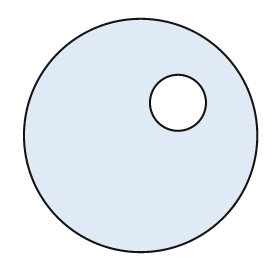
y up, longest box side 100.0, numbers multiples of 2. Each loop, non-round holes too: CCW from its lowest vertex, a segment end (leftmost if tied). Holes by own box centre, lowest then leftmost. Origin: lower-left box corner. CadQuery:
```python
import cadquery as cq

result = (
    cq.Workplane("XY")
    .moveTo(50.0, 50.0)
    .circle(50.0)
    .moveTo(66.0, 64.0)
    .circle(12.0)
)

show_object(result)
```